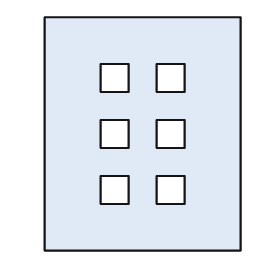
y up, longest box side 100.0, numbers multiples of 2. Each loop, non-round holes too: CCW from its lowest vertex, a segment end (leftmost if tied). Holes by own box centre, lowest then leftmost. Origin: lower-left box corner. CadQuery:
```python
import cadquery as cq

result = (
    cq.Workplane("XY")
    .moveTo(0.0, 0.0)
    .lineTo(84.0, 0.0)
    .lineTo(84.0, 100.0)
    .lineTo(0.0, 100.0)
    .close()
    .moveTo(24.0, 20.0)
    .lineTo(36.0, 20.0)
    .lineTo(36.0, 32.0)
    .lineTo(24.0, 32.0)
    .close()
    .moveTo(48.0, 20.0)
    .lineTo(60.0, 20.0)
    .lineTo(60.0, 32.0)
    .lineTo(48.0, 32.0)
    .close()
    .moveTo(24.0, 44.0)
    .lineTo(36.0, 44.0)
    .lineTo(36.0, 56.0)
    .lineTo(24.0, 56.0)
    .close()
    .moveTo(48.0, 44.0)
    .lineTo(60.0, 44.0)
    .lineTo(60.0, 56.0)
    .lineTo(48.0, 56.0)
    .close()
    .moveTo(24.0, 68.0)
    .lineTo(36.0, 68.0)
    .lineTo(36.0, 80.0)
    .lineTo(24.0, 80.0)
    .close()
    .moveTo(48.0, 68.0)
    .lineTo(60.0, 68.0)
    .lineTo(60.0, 80.0)
    .lineTo(48.0, 80.0)
    .close()
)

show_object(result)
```